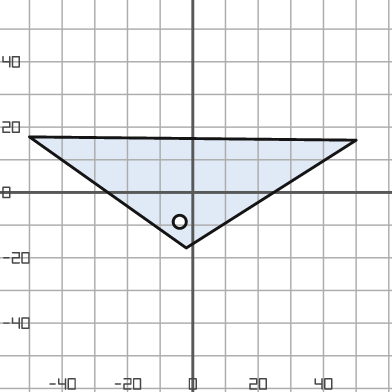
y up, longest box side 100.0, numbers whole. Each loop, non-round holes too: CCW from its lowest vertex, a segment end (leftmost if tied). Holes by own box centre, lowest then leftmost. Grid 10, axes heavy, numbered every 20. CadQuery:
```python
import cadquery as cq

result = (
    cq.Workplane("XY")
    .moveTo(-2.0, -17.0)
    .lineTo(50.0, 16.0)
    .lineTo(-50.0, 17.0)
    .close()
    .moveTo(-4.0, -9.0)
    .circle(2.0)
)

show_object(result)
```